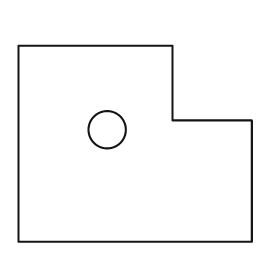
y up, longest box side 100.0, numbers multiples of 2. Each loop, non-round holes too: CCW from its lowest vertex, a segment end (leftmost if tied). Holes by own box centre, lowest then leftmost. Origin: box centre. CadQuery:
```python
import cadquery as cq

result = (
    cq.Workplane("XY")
    .moveTo(-50.0, -42.0)
    .lineTo(50.0, -42.0)
    .lineTo(50.0, 10.0)
    .lineTo(16.0, 10.0)
    .lineTo(16.0, 42.0)
    .lineTo(-50.0, 42.0)
    .close()
    .moveTo(-12.0, 6.0)
    .circle(8.0)
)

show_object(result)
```